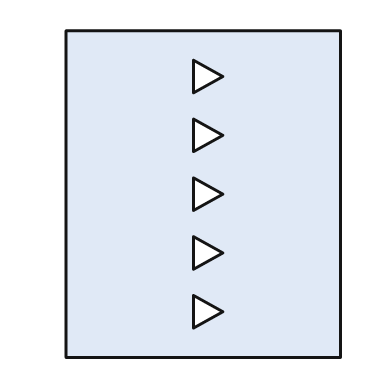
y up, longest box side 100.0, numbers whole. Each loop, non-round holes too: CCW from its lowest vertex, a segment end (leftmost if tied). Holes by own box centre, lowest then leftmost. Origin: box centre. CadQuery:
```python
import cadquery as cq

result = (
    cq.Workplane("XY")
    .moveTo(-42.0, -50.0)
    .lineTo(42.0, -50.0)
    .lineTo(42.0, 50.0)
    .lineTo(-42.0, 50.0)
    .close()
    .moveTo(-3.0, -41.0)
    .lineTo(6.0, -36.0)
    .lineTo(-3.0, -31.0)
    .close()
    .moveTo(-3.0, -23.0)
    .lineTo(6.0, -18.0)
    .lineTo(-3.0, -13.0)
    .close()
    .moveTo(-3.0, -5.0)
    .lineTo(6.0, 0.0)
    .lineTo(-3.0, 5.0)
    .close()
    .moveTo(-3.0, 13.0)
    .lineTo(6.0, 18.0)
    .lineTo(-3.0, 23.0)
    .close()
    .moveTo(-3.0, 31.0)
    .lineTo(6.0, 36.0)
    .lineTo(-3.0, 41.0)
    .close()
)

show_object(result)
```